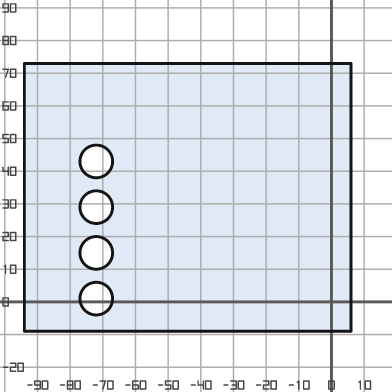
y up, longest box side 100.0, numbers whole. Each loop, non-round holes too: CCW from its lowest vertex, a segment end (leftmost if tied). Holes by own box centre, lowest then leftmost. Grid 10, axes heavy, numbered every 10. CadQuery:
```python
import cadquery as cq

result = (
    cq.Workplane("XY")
    .moveTo(-94.0, -9.0)
    .lineTo(6.0, -9.0)
    .lineTo(6.0, 73.0)
    .lineTo(-94.0, 73.0)
    .close()
    .moveTo(-72.0, 1.0)
    .circle(5.0)
    .moveTo(-72.0, 15.0)
    .circle(5.0)
    .moveTo(-72.0, 29.0)
    .circle(5.0)
    .moveTo(-72.0, 43.0)
    .circle(5.0)
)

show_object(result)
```